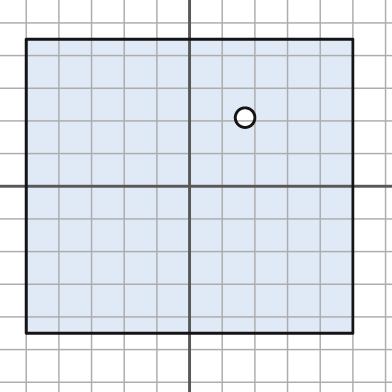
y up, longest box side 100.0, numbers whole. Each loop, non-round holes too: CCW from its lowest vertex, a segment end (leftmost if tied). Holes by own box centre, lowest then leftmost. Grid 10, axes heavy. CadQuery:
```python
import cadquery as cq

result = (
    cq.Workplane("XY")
    .moveTo(-50.0, -45.0)
    .lineTo(50.0, -45.0)
    .lineTo(50.0, 45.0)
    .lineTo(-50.0, 45.0)
    .close()
    .moveTo(17.0, 21.0)
    .circle(3.0)
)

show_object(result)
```